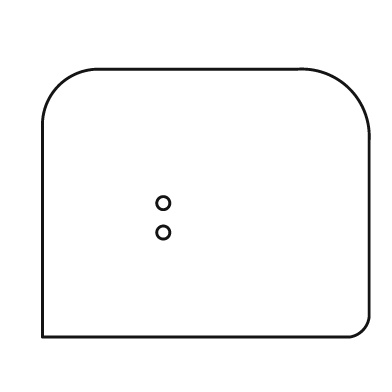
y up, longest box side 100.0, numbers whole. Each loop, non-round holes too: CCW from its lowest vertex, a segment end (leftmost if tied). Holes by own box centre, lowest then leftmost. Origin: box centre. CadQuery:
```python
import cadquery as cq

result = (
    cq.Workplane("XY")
    .moveTo(-50.0, -41.0)
    .lineTo(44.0, -41.0)
    .threePointArc((48.0, -39.0), (50.0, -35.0))
    .lineTo(50.0, 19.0)
    .threePointArc((44.0, 35.0), (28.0, 41.0))
    .lineTo(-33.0, 41.0)
    .threePointArc((-45.0, 36.0), (-50.0, 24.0))
    .close()
    .moveTo(-13.0, -9.0)
    .circle(2.0)
    .moveTo(-13.0, 0.0)
    .circle(2.0)
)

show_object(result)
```